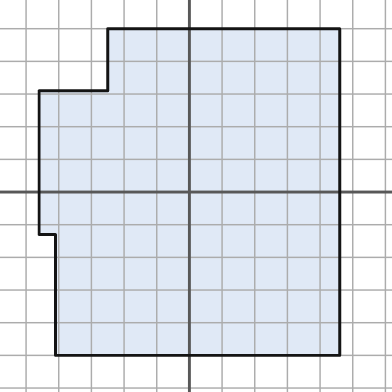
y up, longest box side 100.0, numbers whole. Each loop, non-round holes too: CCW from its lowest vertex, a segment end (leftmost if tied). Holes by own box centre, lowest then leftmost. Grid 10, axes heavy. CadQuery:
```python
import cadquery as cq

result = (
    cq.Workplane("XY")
    .moveTo(-41.0, -50.0)
    .lineTo(46.0, -50.0)
    .lineTo(46.0, 50.0)
    .lineTo(-25.0, 50.0)
    .lineTo(-25.0, 31.0)
    .lineTo(-46.0, 31.0)
    .lineTo(-46.0, -13.0)
    .lineTo(-41.0, -13.0)
    .close()
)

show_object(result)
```